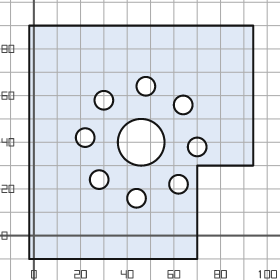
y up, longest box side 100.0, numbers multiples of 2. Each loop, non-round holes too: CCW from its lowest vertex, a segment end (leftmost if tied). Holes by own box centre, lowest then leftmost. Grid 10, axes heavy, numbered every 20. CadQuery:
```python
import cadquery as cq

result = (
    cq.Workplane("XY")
    .moveTo(-2.0, -10.0)
    .lineTo(70.0, -10.0)
    .lineTo(70.0, 30.0)
    .lineTo(94.0, 30.0)
    .lineTo(94.0, 90.0)
    .lineTo(-2.0, 90.0)
    .close()
    .moveTo(44.0, 16.0)
    .circle(4.0)
    .moveTo(62.0, 22.0)
    .circle(4.0)
    .moveTo(28.0, 24.0)
    .circle(4.0)
    .moveTo(70.0, 38.0)
    .circle(4.0)
    .moveTo(46.0, 40.0)
    .circle(10.0)
    .moveTo(22.0, 42.0)
    .circle(4.0)
    .moveTo(64.0, 56.0)
    .circle(4.0)
    .moveTo(30.0, 58.0)
    .circle(4.0)
    .moveTo(48.0, 64.0)
    .circle(4.0)
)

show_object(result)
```